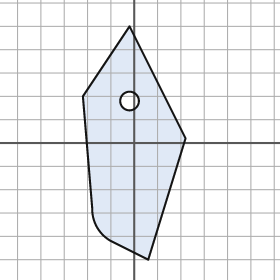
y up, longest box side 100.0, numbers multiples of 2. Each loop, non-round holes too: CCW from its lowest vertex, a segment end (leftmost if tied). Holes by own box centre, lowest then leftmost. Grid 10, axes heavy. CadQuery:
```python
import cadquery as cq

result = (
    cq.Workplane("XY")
    .moveTo(6.0, -50.0)
    .lineTo(22.0, 2.0)
    .lineTo(-2.0, 50.0)
    .lineTo(-22.0, 20.0)
    .lineTo(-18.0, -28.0)
    .threePointArc((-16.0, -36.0), (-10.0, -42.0))
    .close()
    .moveTo(-2.0, 18.0)
    .circle(4.0)
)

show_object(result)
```